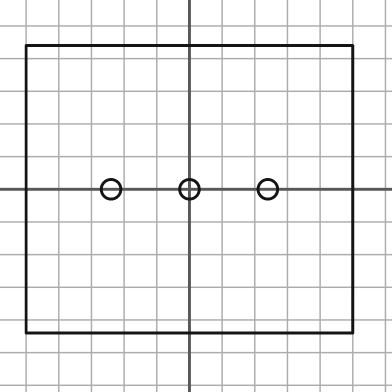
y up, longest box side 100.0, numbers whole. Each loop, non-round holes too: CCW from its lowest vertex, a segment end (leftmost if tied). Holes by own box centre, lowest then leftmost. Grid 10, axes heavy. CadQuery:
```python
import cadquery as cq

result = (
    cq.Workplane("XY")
    .moveTo(-50.0, -44.0)
    .lineTo(50.0, -44.0)
    .lineTo(50.0, 44.0)
    .lineTo(-50.0, 44.0)
    .close()
    .moveTo(-24.0, 0.0)
    .circle(3.0)
    .moveTo(0.0, 0.0)
    .circle(3.0)
    .moveTo(24.0, 0.0)
    .circle(3.0)
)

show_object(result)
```